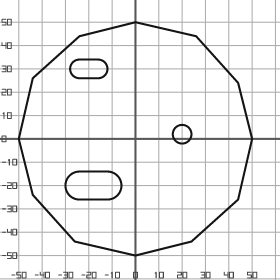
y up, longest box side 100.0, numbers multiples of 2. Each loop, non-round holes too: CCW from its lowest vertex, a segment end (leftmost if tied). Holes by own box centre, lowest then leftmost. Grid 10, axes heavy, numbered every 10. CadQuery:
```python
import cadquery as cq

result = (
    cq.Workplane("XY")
    .moveTo(0.0, -50.0)
    .lineTo(24.0, -44.0)
    .lineTo(44.0, -26.0)
    .lineTo(50.0, 0.0)
    .lineTo(44.0, 24.0)
    .lineTo(26.0, 44.0)
    .lineTo(0.0, 50.0)
    .lineTo(-24.0, 44.0)
    .lineTo(-44.0, 26.0)
    .lineTo(-50.0, 0.0)
    .lineTo(-44.0, -24.0)
    .lineTo(-26.0, -44.0)
    .close()
    .moveTo(-24.0, -26.0)
    .lineTo(-12.0, -26.0)
    .threePointArc((-6.0, -20.0), (-12.0, -14.0))
    .lineTo(-24.0, -14.0)
    .threePointArc((-30.0, -20.0), (-24.0, -26.0))
    .close()
    .moveTo(20.0, 2.0)
    .circle(4.0)
    .moveTo(-24.0, 26.0)
    .lineTo(-16.0, 26.0)
    .threePointArc((-12.0, 30.0), (-16.0, 34.0))
    .lineTo(-24.0, 34.0)
    .threePointArc((-28.0, 30.0), (-24.0, 26.0))
    .close()
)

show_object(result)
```